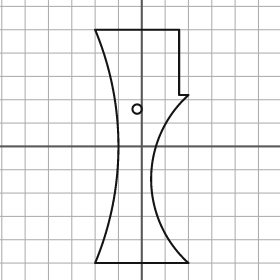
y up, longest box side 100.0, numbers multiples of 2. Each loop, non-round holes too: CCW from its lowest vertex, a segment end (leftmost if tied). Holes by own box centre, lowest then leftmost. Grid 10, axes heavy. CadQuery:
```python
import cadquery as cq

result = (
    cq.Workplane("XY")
    .moveTo(-20.0, -50.0)
    .lineTo(20.0, -50.0)
    .threePointArc((4.0, -14.0), (20.0, 22.0))
    .lineTo(16.0, 22.0)
    .lineTo(16.0, 50.0)
    .lineTo(-20.0, 50.0)
    .threePointArc((-10.0, 0.0), (-20.0, -50.0))
    .close()
    .moveTo(-2.0, 16.0)
    .circle(2.0)
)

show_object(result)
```